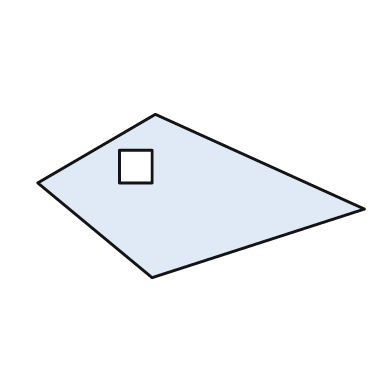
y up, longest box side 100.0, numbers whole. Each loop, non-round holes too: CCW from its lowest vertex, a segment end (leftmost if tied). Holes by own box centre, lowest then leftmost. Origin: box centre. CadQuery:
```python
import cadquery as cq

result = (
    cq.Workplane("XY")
    .moveTo(-15.0, -25.0)
    .lineTo(50.0, -4.0)
    .lineTo(-14.0, 25.0)
    .lineTo(-50.0, 4.0)
    .close()
    .moveTo(-25.0, 4.0)
    .lineTo(-15.0, 4.0)
    .lineTo(-15.0, 14.0)
    .lineTo(-25.0, 14.0)
    .close()
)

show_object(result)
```